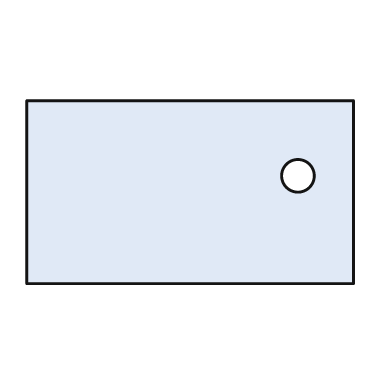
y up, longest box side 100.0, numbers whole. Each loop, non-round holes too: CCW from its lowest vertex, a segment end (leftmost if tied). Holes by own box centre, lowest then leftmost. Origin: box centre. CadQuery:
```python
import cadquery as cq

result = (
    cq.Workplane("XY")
    .moveTo(-50.0, -28.0)
    .lineTo(50.0, -28.0)
    .lineTo(50.0, 28.0)
    .lineTo(-50.0, 28.0)
    .close()
    .moveTo(33.0, 5.0)
    .circle(5.0)
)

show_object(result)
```